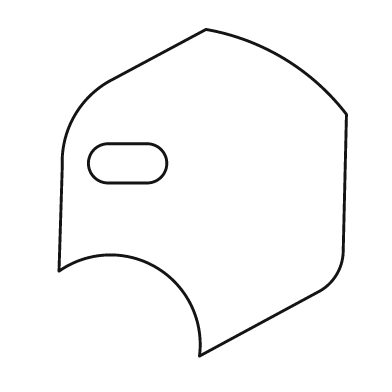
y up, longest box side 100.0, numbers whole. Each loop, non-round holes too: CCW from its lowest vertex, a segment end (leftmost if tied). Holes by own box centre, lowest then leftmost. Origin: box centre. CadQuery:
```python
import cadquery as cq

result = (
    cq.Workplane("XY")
    .moveTo(-1.0, -50.0)
    .lineTo(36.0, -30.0)
    .threePointArc((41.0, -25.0), (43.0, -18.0))
    .lineTo(44.0, 24.0)
    .threePointArc((25.0, 41.0), (1.0, 50.0))
    .lineTo(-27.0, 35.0)
    .threePointArc((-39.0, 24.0), (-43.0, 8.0))
    .lineTo(-44.0, -24.0)
    .threePointArc((-14.0, -23.0), (-1.0, -50.0))
    .close()
    .moveTo(-29.0, 3.0)
    .lineTo(-17.0, 3.0)
    .threePointArc((-11.0, 9.0), (-17.0, 15.0))
    .lineTo(-29.0, 15.0)
    .threePointArc((-35.0, 9.0), (-29.0, 3.0))
    .close()
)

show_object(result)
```